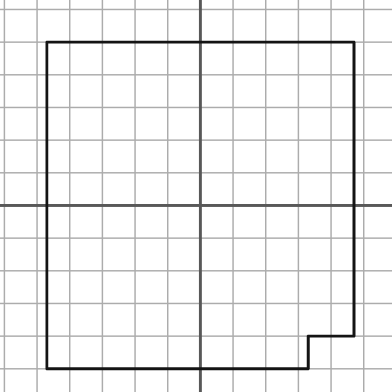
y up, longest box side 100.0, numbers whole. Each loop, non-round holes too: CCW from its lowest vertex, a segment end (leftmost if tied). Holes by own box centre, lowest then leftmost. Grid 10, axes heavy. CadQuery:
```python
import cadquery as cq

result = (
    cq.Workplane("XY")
    .moveTo(-47.0, -50.0)
    .lineTo(33.0, -50.0)
    .lineTo(33.0, -40.0)
    .lineTo(47.0, -40.0)
    .lineTo(47.0, 50.0)
    .lineTo(-47.0, 50.0)
    .close()
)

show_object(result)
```